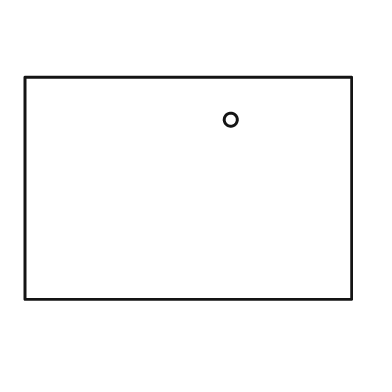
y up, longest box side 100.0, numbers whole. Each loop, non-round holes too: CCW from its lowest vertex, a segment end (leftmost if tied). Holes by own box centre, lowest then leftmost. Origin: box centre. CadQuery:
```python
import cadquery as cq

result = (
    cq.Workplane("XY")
    .moveTo(-50.0, -34.0)
    .lineTo(50.0, -34.0)
    .lineTo(50.0, 34.0)
    .lineTo(-50.0, 34.0)
    .close()
    .moveTo(13.0, 21.0)
    .circle(2.0)
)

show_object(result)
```